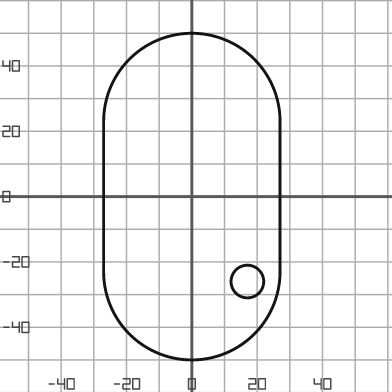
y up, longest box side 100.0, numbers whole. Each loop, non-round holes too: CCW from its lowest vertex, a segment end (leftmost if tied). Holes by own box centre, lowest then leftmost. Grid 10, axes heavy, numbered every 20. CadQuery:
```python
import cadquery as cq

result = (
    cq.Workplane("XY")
    .moveTo(-27.0, -23.0)
    .threePointArc((0.0, -50.0), (27.0, -23.0))
    .lineTo(27.0, 23.0)
    .threePointArc((0.0, 50.0), (-27.0, 23.0))
    .close()
    .moveTo(17.0, -26.0)
    .circle(5.0)
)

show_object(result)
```